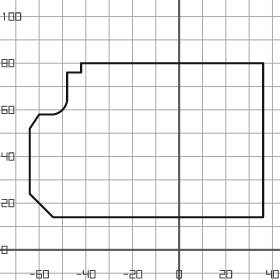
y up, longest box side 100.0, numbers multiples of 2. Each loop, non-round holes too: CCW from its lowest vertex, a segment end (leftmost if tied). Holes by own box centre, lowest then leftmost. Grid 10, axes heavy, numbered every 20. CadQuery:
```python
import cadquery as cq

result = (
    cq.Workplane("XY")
    .moveTo(-54.0, 14.0)
    .lineTo(36.0, 14.0)
    .lineTo(36.0, 80.0)
    .lineTo(-42.0, 80.0)
    .lineTo(-42.0, 76.0)
    .lineTo(-48.0, 76.0)
    .lineTo(-48.0, 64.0)
    .threePointArc((-50.0, 60.0), (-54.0, 58.0))
    .lineTo(-60.0, 58.0)
    .lineTo(-64.0, 52.0)
    .lineTo(-64.0, 24.0)
    .close()
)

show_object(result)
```